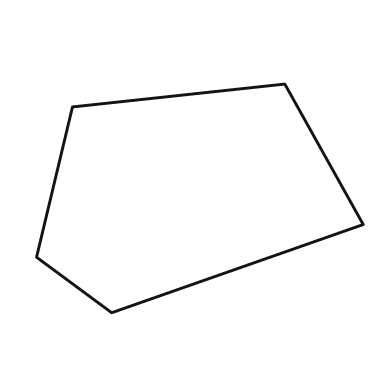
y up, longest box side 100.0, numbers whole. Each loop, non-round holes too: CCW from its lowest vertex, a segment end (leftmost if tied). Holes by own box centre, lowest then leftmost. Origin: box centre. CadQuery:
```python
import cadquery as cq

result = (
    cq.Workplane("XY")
    .moveTo(-27.0, -35.0)
    .lineTo(50.0, -8.0)
    .lineTo(26.0, 35.0)
    .lineTo(-39.0, 28.0)
    .lineTo(-50.0, -18.0)
    .close()
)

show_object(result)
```